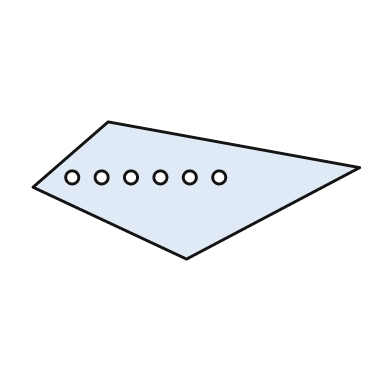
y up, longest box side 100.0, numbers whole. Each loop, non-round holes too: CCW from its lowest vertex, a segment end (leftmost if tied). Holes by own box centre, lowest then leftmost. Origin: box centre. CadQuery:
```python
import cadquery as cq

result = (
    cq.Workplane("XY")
    .moveTo(-3.0, -21.0)
    .lineTo(50.0, 7.0)
    .lineTo(-27.0, 21.0)
    .lineTo(-50.0, 1.0)
    .close()
    .moveTo(-38.0, 4.0)
    .circle(2.0)
    .moveTo(-29.0, 4.0)
    .circle(2.0)
    .moveTo(-20.0, 4.0)
    .circle(2.0)
    .moveTo(-11.0, 4.0)
    .circle(2.0)
    .moveTo(-2.0, 4.0)
    .circle(2.0)
    .moveTo(7.0, 4.0)
    .circle(2.0)
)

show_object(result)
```